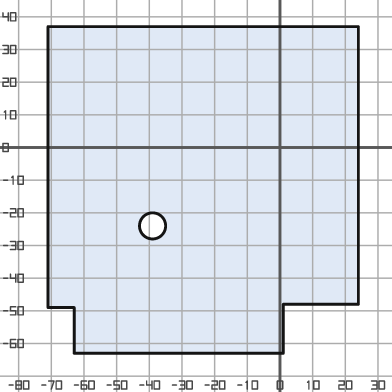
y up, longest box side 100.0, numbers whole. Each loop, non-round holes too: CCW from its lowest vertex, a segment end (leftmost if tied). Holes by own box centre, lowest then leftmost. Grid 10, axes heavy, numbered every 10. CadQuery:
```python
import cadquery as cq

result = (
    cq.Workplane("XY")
    .moveTo(-63.0, -63.0)
    .lineTo(1.0, -63.0)
    .lineTo(1.0, -48.0)
    .lineTo(24.0, -48.0)
    .lineTo(24.0, 37.0)
    .lineTo(-71.0, 37.0)
    .lineTo(-71.0, -49.0)
    .lineTo(-63.0, -49.0)
    .close()
    .moveTo(-39.0, -24.0)
    .circle(4.0)
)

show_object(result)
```